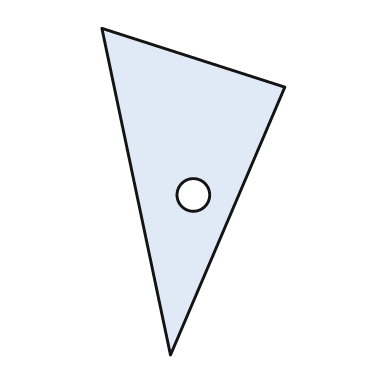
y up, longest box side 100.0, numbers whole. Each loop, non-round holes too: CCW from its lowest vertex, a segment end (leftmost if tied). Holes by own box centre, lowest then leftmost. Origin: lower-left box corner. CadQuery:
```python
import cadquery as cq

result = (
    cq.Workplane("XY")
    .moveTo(21.0, 0.0)
    .lineTo(56.0, 82.0)
    .lineTo(0.0, 100.0)
    .close()
    .moveTo(28.0, 49.0)
    .circle(5.0)
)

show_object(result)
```